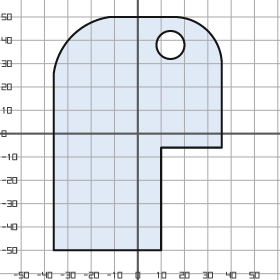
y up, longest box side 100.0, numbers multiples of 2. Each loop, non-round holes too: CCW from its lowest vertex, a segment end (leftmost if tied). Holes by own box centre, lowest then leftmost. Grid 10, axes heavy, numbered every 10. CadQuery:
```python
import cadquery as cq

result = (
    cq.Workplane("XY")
    .moveTo(-36.0, -50.0)
    .lineTo(10.0, -50.0)
    .lineTo(10.0, -6.0)
    .lineTo(36.0, -6.0)
    .lineTo(36.0, 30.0)
    .threePointArc((30.0, 44.0), (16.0, 50.0))
    .lineTo(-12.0, 50.0)
    .threePointArc((-28.0, 42.0), (-36.0, 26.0))
    .close()
    .moveTo(14.0, 38.0)
    .circle(6.0)
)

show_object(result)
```